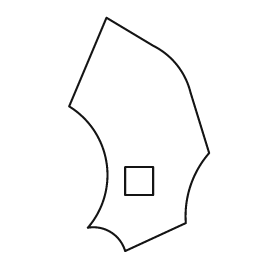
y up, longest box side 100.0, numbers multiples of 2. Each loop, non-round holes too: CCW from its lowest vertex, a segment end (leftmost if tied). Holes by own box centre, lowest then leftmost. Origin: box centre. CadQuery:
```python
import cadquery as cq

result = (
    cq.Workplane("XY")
    .moveTo(-6.0, -50.0)
    .lineTo(20.0, -38.0)
    .threePointArc((22.0, -22.0), (30.0, -8.0))
    .lineTo(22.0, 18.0)
    .threePointArc((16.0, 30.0), (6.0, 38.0))
    .lineTo(-14.0, 50.0)
    .lineTo(-30.0, 12.0)
    .threePointArc((-14.0, -12.0), (-22.0, -40.0))
    .threePointArc((-12.0, -42.0), (-6.0, -50.0))
    .close()
    .moveTo(-6.0, -26.0)
    .lineTo(6.0, -26.0)
    .lineTo(6.0, -14.0)
    .lineTo(-6.0, -14.0)
    .close()
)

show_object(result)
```